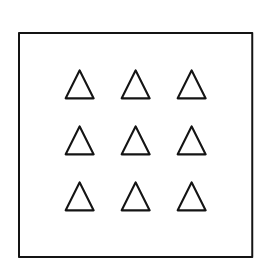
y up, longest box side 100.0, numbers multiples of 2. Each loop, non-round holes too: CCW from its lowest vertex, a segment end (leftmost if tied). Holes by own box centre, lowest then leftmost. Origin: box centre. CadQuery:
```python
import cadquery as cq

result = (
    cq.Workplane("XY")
    .moveTo(-50.0, -48.0)
    .lineTo(50.0, -48.0)
    .lineTo(50.0, 48.0)
    .lineTo(-50.0, 48.0)
    .close()
    .moveTo(-30.0, -28.0)
    .lineTo(-18.0, -28.0)
    .lineTo(-24.0, -16.0)
    .close()
    .moveTo(-6.0, -28.0)
    .lineTo(6.0, -28.0)
    .lineTo(0.0, -16.0)
    .close()
    .moveTo(18.0, -28.0)
    .lineTo(30.0, -28.0)
    .lineTo(24.0, -16.0)
    .close()
    .moveTo(-30.0, -4.0)
    .lineTo(-18.0, -4.0)
    .lineTo(-24.0, 8.0)
    .close()
    .moveTo(-6.0, -4.0)
    .lineTo(6.0, -4.0)
    .lineTo(0.0, 8.0)
    .close()
    .moveTo(18.0, -4.0)
    .lineTo(30.0, -4.0)
    .lineTo(24.0, 8.0)
    .close()
    .moveTo(-30.0, 20.0)
    .lineTo(-18.0, 20.0)
    .lineTo(-24.0, 32.0)
    .close()
    .moveTo(-6.0, 20.0)
    .lineTo(6.0, 20.0)
    .lineTo(0.0, 32.0)
    .close()
    .moveTo(18.0, 20.0)
    .lineTo(30.0, 20.0)
    .lineTo(24.0, 32.0)
    .close()
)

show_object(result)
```